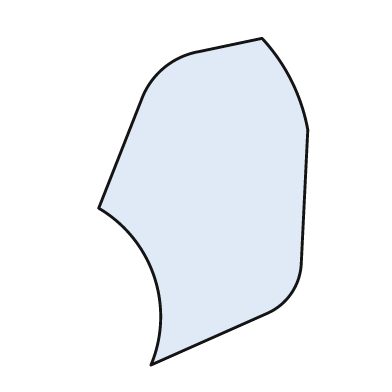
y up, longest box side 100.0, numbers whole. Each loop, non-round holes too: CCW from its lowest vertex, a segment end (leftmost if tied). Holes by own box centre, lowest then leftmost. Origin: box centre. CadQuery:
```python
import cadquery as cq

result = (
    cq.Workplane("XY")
    .moveTo(-16.0, -50.0)
    .lineTo(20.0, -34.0)
    .threePointArc((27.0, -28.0), (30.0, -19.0))
    .lineTo(32.0, 22.0)
    .threePointArc((27.0, 37.0), (18.0, 50.0))
    .lineTo(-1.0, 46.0)
    .threePointArc((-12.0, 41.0), (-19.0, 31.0))
    .lineTo(-32.0, -2.0)
    .threePointArc((-15.0, -23.0), (-16.0, -50.0))
    .close()
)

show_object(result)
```